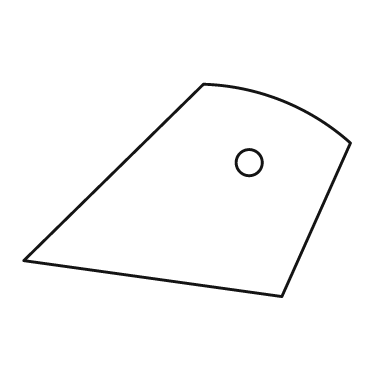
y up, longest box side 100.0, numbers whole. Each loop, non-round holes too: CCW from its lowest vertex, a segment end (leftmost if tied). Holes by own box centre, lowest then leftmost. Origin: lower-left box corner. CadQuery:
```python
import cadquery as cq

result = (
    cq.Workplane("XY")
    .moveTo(79.0, 0.0)
    .lineTo(100.0, 47.0)
    .threePointArc((79.0, 60.0), (55.0, 65.0))
    .lineTo(0.0, 11.0)
    .close()
    .moveTo(69.0, 41.0)
    .circle(4.0)
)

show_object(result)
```